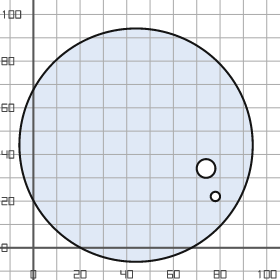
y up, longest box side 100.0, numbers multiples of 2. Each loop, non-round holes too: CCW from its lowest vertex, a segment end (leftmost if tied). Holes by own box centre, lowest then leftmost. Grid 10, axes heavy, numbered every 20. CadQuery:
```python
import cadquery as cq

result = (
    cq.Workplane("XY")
    .moveTo(44.0, 44.0)
    .circle(50.0)
    .moveTo(78.0, 22.0)
    .circle(2.0)
    .moveTo(74.0, 34.0)
    .circle(4.0)
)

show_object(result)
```